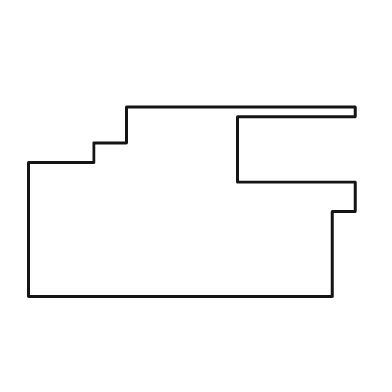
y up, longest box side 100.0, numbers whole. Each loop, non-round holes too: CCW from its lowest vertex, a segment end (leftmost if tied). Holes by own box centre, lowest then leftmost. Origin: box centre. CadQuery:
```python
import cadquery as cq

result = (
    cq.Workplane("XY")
    .moveTo(-50.0, -29.0)
    .lineTo(43.0, -29.0)
    .lineTo(43.0, -3.0)
    .lineTo(50.0, -3.0)
    .lineTo(50.0, 6.0)
    .lineTo(14.0, 6.0)
    .lineTo(14.0, 26.0)
    .lineTo(50.0, 26.0)
    .lineTo(50.0, 29.0)
    .lineTo(-20.0, 29.0)
    .lineTo(-20.0, 18.0)
    .lineTo(-30.0, 18.0)
    .lineTo(-30.0, 12.0)
    .lineTo(-50.0, 12.0)
    .close()
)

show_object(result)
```